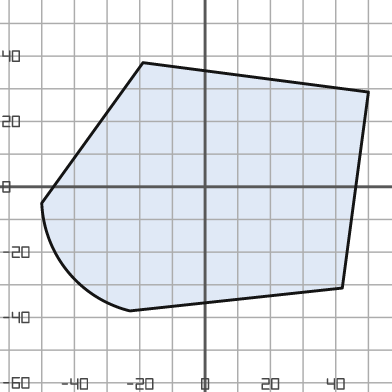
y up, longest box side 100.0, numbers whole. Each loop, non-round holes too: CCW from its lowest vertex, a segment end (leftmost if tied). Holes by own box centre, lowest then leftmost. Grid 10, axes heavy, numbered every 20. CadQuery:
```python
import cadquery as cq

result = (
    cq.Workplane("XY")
    .moveTo(-23.0, -38.0)
    .lineTo(42.0, -31.0)
    .lineTo(50.0, 29.0)
    .lineTo(-19.0, 38.0)
    .lineTo(-50.0, -5.0)
    .threePointArc((-42.0, -26.0), (-23.0, -38.0))
    .close()
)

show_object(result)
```